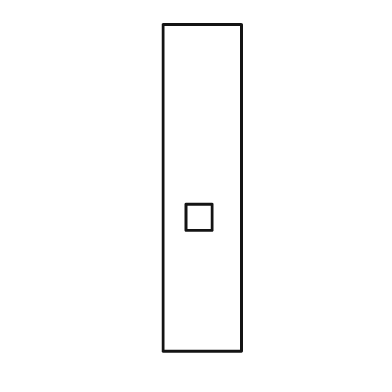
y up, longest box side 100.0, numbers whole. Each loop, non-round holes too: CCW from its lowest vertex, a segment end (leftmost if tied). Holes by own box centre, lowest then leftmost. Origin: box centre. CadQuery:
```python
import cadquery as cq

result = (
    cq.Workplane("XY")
    .moveTo(-12.0, -50.0)
    .lineTo(12.0, -50.0)
    .lineTo(12.0, 50.0)
    .lineTo(-12.0, 50.0)
    .close()
    .moveTo(-5.0, -13.0)
    .lineTo(3.0, -13.0)
    .lineTo(3.0, -5.0)
    .lineTo(-5.0, -5.0)
    .close()
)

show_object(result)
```